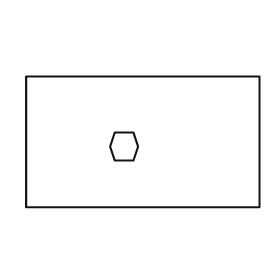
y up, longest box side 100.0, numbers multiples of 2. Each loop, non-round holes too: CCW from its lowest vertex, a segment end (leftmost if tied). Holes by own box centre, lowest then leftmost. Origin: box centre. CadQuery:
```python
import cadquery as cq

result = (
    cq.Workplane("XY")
    .moveTo(-50.0, -28.0)
    .lineTo(50.0, -28.0)
    .lineTo(50.0, 28.0)
    .lineTo(-50.0, 28.0)
    .close()
    .moveTo(-12.0, -8.0)
    .lineTo(-4.0, -8.0)
    .lineTo(-2.0, -2.0)
    .lineTo(-4.0, 4.0)
    .lineTo(-12.0, 4.0)
    .lineTo(-14.0, -2.0)
    .close()
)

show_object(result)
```